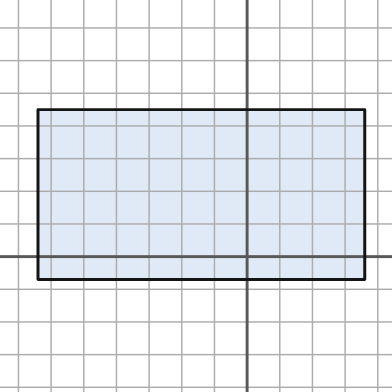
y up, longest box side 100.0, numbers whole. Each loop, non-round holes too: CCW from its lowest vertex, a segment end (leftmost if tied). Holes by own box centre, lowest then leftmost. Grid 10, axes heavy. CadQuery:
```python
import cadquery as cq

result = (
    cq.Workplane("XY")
    .moveTo(-64.0, -7.0)
    .lineTo(36.0, -7.0)
    .lineTo(36.0, 45.0)
    .lineTo(-64.0, 45.0)
    .close()
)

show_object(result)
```